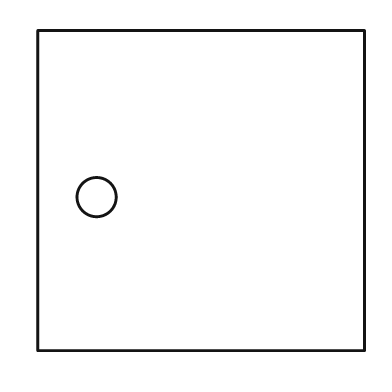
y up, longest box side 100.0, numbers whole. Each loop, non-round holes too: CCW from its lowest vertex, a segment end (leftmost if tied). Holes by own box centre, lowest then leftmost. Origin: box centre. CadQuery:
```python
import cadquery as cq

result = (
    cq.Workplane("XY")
    .moveTo(-50.0, -49.0)
    .lineTo(50.0, -49.0)
    .lineTo(50.0, 49.0)
    .lineTo(-50.0, 49.0)
    .close()
    .moveTo(-32.0, -2.0)
    .circle(6.0)
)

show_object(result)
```